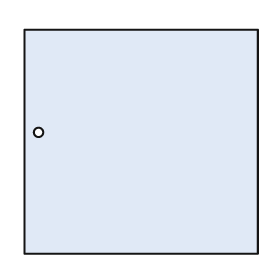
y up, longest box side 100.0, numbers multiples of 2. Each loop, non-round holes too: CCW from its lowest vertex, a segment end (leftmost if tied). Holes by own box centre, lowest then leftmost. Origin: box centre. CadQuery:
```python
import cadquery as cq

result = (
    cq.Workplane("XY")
    .moveTo(-50.0, -48.0)
    .lineTo(50.0, -48.0)
    .lineTo(50.0, 48.0)
    .lineTo(-50.0, 48.0)
    .close()
    .moveTo(-44.0, 4.0)
    .circle(2.0)
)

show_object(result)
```